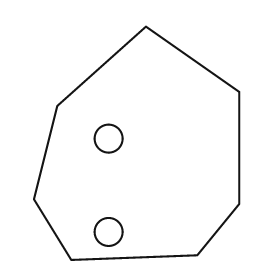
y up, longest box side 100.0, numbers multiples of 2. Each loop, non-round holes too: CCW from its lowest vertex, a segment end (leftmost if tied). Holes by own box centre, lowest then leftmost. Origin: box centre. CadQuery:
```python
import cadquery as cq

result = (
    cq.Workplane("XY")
    .moveTo(-28.0, -50.0)
    .lineTo(26.0, -48.0)
    .lineTo(44.0, -26.0)
    .lineTo(44.0, 22.0)
    .lineTo(4.0, 50.0)
    .lineTo(-34.0, 16.0)
    .lineTo(-44.0, -24.0)
    .close()
    .moveTo(-12.0, -38.0)
    .circle(6.0)
    .moveTo(-12.0, 2.0)
    .circle(6.0)
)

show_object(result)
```